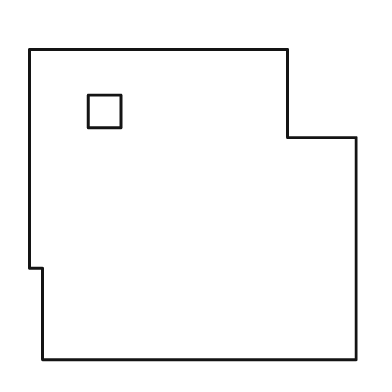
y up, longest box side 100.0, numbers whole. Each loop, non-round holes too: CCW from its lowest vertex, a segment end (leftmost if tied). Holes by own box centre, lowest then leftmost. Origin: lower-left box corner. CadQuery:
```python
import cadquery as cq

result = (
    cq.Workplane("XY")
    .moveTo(4.0, 0.0)
    .lineTo(100.0, 0.0)
    .lineTo(100.0, 68.0)
    .lineTo(79.0, 68.0)
    .lineTo(79.0, 95.0)
    .lineTo(0.0, 95.0)
    .lineTo(0.0, 28.0)
    .lineTo(4.0, 28.0)
    .close()
    .moveTo(18.0, 71.0)
    .lineTo(28.0, 71.0)
    .lineTo(28.0, 81.0)
    .lineTo(18.0, 81.0)
    .close()
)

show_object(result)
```